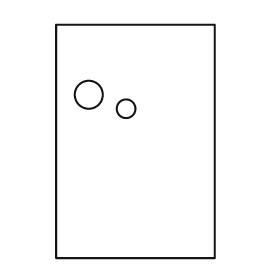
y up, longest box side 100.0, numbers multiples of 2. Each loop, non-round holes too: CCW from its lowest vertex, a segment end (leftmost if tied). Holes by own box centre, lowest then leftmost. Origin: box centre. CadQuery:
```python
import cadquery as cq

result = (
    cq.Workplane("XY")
    .moveTo(-34.0, -50.0)
    .lineTo(34.0, -50.0)
    .lineTo(34.0, 50.0)
    .lineTo(-34.0, 50.0)
    .close()
    .moveTo(-4.0, 14.0)
    .circle(4.0)
    .moveTo(-20.0, 20.0)
    .circle(6.0)
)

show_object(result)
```